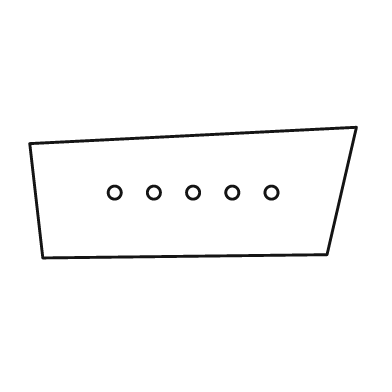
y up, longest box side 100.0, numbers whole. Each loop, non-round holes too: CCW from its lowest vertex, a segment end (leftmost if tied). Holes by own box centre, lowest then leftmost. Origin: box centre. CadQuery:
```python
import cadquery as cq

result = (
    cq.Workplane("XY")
    .moveTo(-46.0, -20.0)
    .lineTo(41.0, -19.0)
    .lineTo(50.0, 20.0)
    .lineTo(-50.0, 15.0)
    .close()
    .moveTo(-24.0, 0.0)
    .circle(2.0)
    .moveTo(-12.0, 0.0)
    .circle(2.0)
    .moveTo(0.0, 0.0)
    .circle(2.0)
    .moveTo(12.0, 0.0)
    .circle(2.0)
    .moveTo(24.0, 0.0)
    .circle(2.0)
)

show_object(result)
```